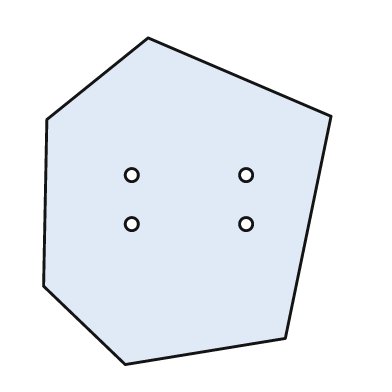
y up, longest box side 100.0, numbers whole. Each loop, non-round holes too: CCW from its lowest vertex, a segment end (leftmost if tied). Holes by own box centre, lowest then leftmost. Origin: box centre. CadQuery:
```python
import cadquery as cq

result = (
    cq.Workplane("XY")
    .moveTo(-19.0, -50.0)
    .lineTo(30.0, -42.0)
    .lineTo(44.0, 26.0)
    .lineTo(-12.0, 50.0)
    .lineTo(-43.0, 25.0)
    .lineTo(-44.0, -26.0)
    .close()
    .moveTo(-17.0, -7.0)
    .circle(2.0)
    .moveTo(18.0, -7.0)
    .circle(2.0)
    .moveTo(-17.0, 8.0)
    .circle(2.0)
    .moveTo(18.0, 8.0)
    .circle(2.0)
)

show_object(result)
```